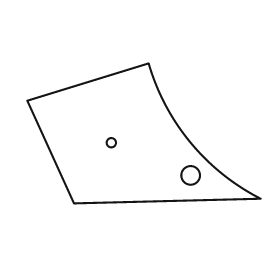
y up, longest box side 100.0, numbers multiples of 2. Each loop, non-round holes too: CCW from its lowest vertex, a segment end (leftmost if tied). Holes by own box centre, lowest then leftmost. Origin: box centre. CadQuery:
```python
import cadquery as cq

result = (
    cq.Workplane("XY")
    .moveTo(-30.0, -30.0)
    .lineTo(50.0, -28.0)
    .threePointArc((20.0, -4.0), (2.0, 30.0))
    .lineTo(-50.0, 14.0)
    .close()
    .moveTo(20.0, -18.0)
    .circle(4.0)
    .moveTo(-14.0, -4.0)
    .circle(2.0)
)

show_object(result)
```